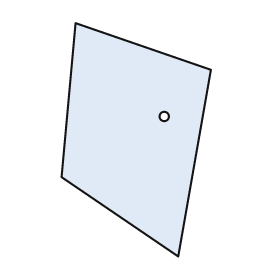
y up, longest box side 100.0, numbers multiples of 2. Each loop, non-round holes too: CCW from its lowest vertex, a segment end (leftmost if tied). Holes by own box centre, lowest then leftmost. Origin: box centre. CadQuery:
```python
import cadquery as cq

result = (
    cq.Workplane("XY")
    .moveTo(18.0, -50.0)
    .lineTo(32.0, 30.0)
    .lineTo(-26.0, 50.0)
    .lineTo(-32.0, -16.0)
    .close()
    .moveTo(12.0, 10.0)
    .circle(2.0)
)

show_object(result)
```